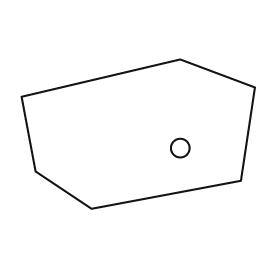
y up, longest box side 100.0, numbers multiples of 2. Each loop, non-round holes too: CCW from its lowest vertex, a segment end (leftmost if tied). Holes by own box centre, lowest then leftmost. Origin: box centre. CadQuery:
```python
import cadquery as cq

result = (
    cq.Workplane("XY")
    .moveTo(-20.0, -32.0)
    .lineTo(44.0, -20.0)
    .lineTo(50.0, 20.0)
    .lineTo(18.0, 32.0)
    .lineTo(-50.0, 16.0)
    .lineTo(-44.0, -16.0)
    .close()
    .moveTo(18.0, -6.0)
    .circle(4.0)
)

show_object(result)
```